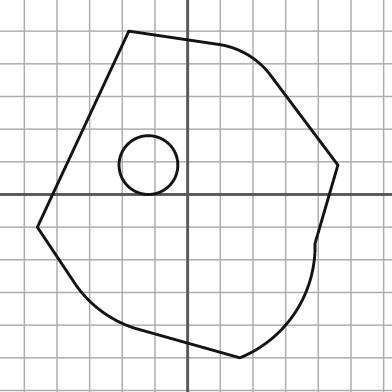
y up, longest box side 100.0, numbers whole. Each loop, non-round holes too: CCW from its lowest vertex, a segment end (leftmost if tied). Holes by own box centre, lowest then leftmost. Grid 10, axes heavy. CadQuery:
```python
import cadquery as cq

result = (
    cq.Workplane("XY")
    .moveTo(16.0, -50.0)
    .threePointArc((33.0, -36.0), (39.0, -15.0))
    .lineTo(46.0, 9.0)
    .lineTo(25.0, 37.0)
    .threePointArc((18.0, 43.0), (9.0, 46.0))
    .lineTo(-18.0, 50.0)
    .lineTo(-46.0, -10.0)
    .lineTo(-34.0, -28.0)
    .threePointArc((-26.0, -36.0), (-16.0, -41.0))
    .close()
    .moveTo(-12.0, 9.0)
    .circle(9.0)
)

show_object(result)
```